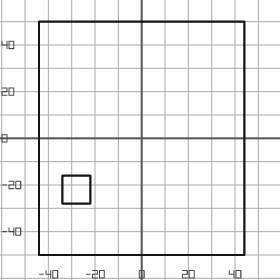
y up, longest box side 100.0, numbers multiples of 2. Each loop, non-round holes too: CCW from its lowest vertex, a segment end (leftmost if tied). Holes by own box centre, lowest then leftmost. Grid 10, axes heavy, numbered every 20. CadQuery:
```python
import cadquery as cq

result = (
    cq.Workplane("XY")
    .moveTo(-44.0, -50.0)
    .lineTo(44.0, -50.0)
    .lineTo(44.0, 50.0)
    .lineTo(-44.0, 50.0)
    .close()
    .moveTo(-34.0, -28.0)
    .lineTo(-22.0, -28.0)
    .lineTo(-22.0, -16.0)
    .lineTo(-34.0, -16.0)
    .close()
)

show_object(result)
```